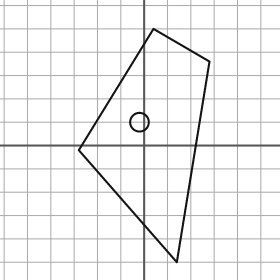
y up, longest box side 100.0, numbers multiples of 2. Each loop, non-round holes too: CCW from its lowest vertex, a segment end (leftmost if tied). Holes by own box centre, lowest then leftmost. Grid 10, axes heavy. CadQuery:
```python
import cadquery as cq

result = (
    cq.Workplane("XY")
    .moveTo(14.0, -50.0)
    .lineTo(28.0, 36.0)
    .lineTo(4.0, 50.0)
    .lineTo(-28.0, -2.0)
    .close()
    .moveTo(-2.0, 10.0)
    .circle(4.0)
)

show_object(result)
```